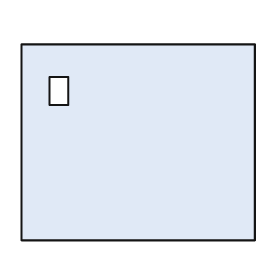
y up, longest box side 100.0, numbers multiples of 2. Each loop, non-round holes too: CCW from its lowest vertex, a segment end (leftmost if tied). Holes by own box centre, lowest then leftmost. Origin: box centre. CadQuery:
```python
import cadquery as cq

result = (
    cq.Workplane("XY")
    .moveTo(-50.0, -42.0)
    .lineTo(50.0, -42.0)
    .lineTo(50.0, 42.0)
    .lineTo(-50.0, 42.0)
    .close()
    .moveTo(-38.0, 16.0)
    .lineTo(-30.0, 16.0)
    .lineTo(-30.0, 28.0)
    .lineTo(-38.0, 28.0)
    .close()
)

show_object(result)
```